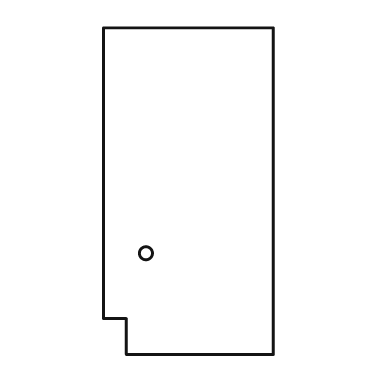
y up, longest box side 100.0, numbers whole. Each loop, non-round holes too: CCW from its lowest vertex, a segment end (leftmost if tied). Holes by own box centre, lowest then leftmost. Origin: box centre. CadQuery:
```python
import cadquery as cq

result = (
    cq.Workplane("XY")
    .moveTo(-19.0, -50.0)
    .lineTo(26.0, -50.0)
    .lineTo(26.0, 50.0)
    .lineTo(-26.0, 50.0)
    .lineTo(-26.0, -39.0)
    .lineTo(-19.0, -39.0)
    .close()
    .moveTo(-13.0, -19.0)
    .circle(2.0)
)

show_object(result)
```